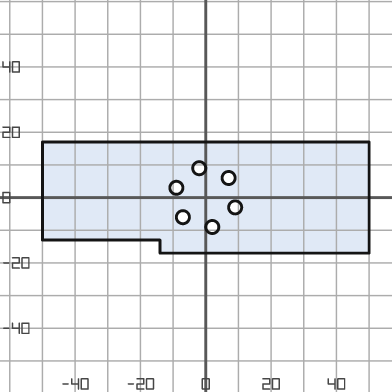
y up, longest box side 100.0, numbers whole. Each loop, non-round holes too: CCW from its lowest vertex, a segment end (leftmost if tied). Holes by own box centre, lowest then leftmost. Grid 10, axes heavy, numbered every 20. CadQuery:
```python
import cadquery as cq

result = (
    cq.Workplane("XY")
    .moveTo(-14.0, -17.0)
    .lineTo(50.0, -17.0)
    .lineTo(50.0, 17.0)
    .lineTo(-50.0, 17.0)
    .lineTo(-50.0, -13.0)
    .lineTo(-14.0, -13.0)
    .close()
    .moveTo(2.0, -9.0)
    .circle(2.0)
    .moveTo(-7.0, -6.0)
    .circle(2.0)
    .moveTo(9.0, -3.0)
    .circle(2.0)
    .moveTo(-9.0, 3.0)
    .circle(2.0)
    .moveTo(7.0, 6.0)
    .circle(2.0)
    .moveTo(-2.0, 9.0)
    .circle(2.0)
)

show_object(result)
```